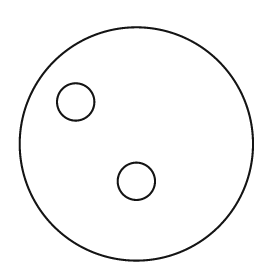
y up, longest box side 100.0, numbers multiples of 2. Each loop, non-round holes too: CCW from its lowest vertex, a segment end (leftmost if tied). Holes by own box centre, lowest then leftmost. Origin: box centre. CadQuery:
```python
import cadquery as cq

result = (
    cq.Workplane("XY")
    .moveTo(0.0, 0.0)
    .circle(50.0)
    .moveTo(0.0, -16.0)
    .circle(8.0)
    .moveTo(-26.0, 18.0)
    .circle(8.0)
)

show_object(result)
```